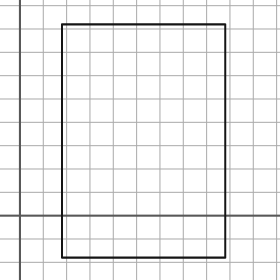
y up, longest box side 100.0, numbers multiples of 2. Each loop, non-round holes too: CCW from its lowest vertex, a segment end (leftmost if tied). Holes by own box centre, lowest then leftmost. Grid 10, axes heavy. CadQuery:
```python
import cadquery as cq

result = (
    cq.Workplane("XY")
    .moveTo(18.0, -18.0)
    .lineTo(88.0, -18.0)
    .lineTo(88.0, 82.0)
    .lineTo(18.0, 82.0)
    .close()
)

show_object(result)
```